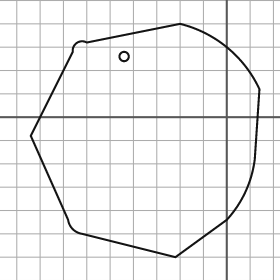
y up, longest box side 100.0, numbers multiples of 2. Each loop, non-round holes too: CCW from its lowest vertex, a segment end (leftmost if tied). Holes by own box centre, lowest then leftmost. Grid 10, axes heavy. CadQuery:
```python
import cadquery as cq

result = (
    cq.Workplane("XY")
    .moveTo(-22.0, -60.0)
    .lineTo(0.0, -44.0)
    .threePointArc((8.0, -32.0), (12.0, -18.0))
    .lineTo(14.0, 12.0)
    .threePointArc((0.0, 30.0), (-20.0, 40.0))
    .lineTo(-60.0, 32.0)
    .threePointArc((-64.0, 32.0), (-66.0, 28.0))
    .lineTo(-84.0, -8.0)
    .lineTo(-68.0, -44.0)
    .threePointArc((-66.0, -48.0), (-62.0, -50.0))
    .close()
    .moveTo(-44.0, 26.0)
    .circle(2.0)
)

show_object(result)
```